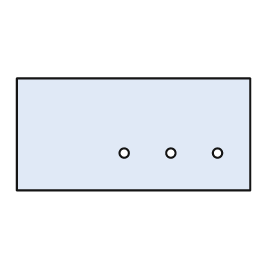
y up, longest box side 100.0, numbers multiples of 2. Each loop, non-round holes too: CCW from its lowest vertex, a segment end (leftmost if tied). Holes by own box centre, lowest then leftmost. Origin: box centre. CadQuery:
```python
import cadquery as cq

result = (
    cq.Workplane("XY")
    .moveTo(-50.0, -24.0)
    .lineTo(50.0, -24.0)
    .lineTo(50.0, 24.0)
    .lineTo(-50.0, 24.0)
    .close()
    .moveTo(-4.0, -8.0)
    .circle(2.0)
    .moveTo(16.0, -8.0)
    .circle(2.0)
    .moveTo(36.0, -8.0)
    .circle(2.0)
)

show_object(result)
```